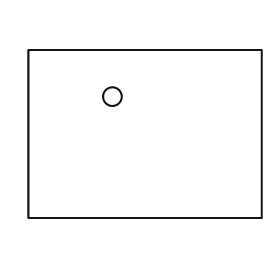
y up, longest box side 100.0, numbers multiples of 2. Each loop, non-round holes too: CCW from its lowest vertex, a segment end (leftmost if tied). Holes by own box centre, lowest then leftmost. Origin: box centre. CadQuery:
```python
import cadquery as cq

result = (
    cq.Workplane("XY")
    .moveTo(-50.0, -36.0)
    .lineTo(50.0, -36.0)
    .lineTo(50.0, 36.0)
    .lineTo(-50.0, 36.0)
    .close()
    .moveTo(-14.0, 16.0)
    .circle(4.0)
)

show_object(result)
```